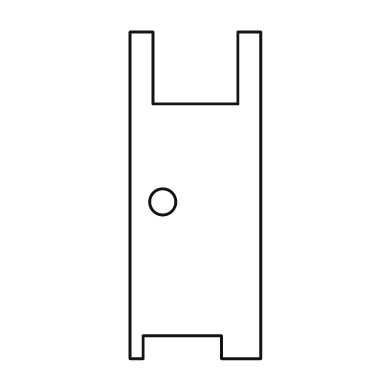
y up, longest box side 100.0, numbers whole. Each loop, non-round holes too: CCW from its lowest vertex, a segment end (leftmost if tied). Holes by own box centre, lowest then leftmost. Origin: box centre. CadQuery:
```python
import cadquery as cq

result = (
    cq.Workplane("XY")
    .moveTo(-20.0, -50.0)
    .lineTo(-16.0, -50.0)
    .lineTo(-16.0, -43.0)
    .lineTo(8.0, -43.0)
    .lineTo(8.0, -50.0)
    .lineTo(20.0, -50.0)
    .lineTo(20.0, 50.0)
    .lineTo(13.0, 50.0)
    .lineTo(13.0, 28.0)
    .lineTo(-13.0, 28.0)
    .lineTo(-13.0, 50.0)
    .lineTo(-20.0, 50.0)
    .close()
    .moveTo(-10.0, -2.0)
    .circle(4.0)
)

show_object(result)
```